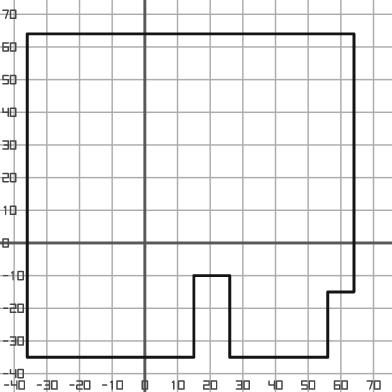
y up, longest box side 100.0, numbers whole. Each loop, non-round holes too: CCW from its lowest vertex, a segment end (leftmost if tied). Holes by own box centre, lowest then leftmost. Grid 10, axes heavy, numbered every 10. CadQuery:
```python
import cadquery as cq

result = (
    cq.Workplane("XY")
    .moveTo(-36.0, -35.0)
    .lineTo(15.0, -35.0)
    .lineTo(15.0, -10.0)
    .lineTo(26.0, -10.0)
    .lineTo(26.0, -35.0)
    .lineTo(56.0, -35.0)
    .lineTo(56.0, -15.0)
    .lineTo(64.0, -15.0)
    .lineTo(64.0, 64.0)
    .lineTo(-36.0, 64.0)
    .close()
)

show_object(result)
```